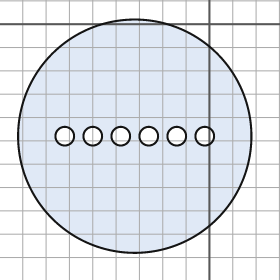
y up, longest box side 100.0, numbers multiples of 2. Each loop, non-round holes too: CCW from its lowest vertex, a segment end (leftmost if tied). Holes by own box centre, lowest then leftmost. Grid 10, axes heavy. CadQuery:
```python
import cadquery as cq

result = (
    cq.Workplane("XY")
    .moveTo(-32.0, -48.0)
    .circle(50.0)
    .moveTo(-62.0, -48.0)
    .circle(4.0)
    .moveTo(-50.0, -48.0)
    .circle(4.0)
    .moveTo(-38.0, -48.0)
    .circle(4.0)
    .moveTo(-26.0, -48.0)
    .circle(4.0)
    .moveTo(-14.0, -48.0)
    .circle(4.0)
    .moveTo(-2.0, -48.0)
    .circle(4.0)
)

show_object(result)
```